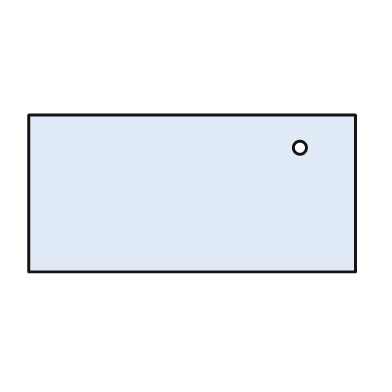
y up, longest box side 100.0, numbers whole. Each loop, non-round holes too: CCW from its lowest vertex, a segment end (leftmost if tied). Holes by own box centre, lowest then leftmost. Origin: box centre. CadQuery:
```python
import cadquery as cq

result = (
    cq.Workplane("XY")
    .moveTo(-50.0, -24.0)
    .lineTo(50.0, -24.0)
    .lineTo(50.0, 24.0)
    .lineTo(-50.0, 24.0)
    .close()
    .moveTo(33.0, 14.0)
    .circle(2.0)
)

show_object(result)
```